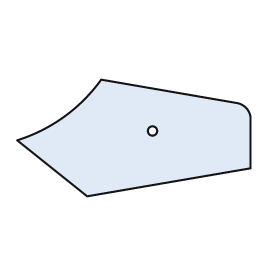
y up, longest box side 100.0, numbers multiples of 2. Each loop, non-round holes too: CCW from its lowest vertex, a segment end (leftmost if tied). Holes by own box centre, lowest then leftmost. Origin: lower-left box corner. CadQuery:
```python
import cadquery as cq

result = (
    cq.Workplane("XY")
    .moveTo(30.0, 0.0)
    .lineTo(100.0, 12.0)
    .lineTo(100.0, 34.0)
    .threePointArc((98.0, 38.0), (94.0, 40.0))
    .lineTo(36.0, 50.0)
    .threePointArc((20.0, 34.0), (0.0, 24.0))
    .close()
    .moveTo(58.0, 28.0)
    .circle(2.0)
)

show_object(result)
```